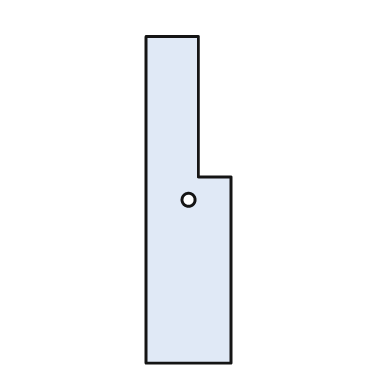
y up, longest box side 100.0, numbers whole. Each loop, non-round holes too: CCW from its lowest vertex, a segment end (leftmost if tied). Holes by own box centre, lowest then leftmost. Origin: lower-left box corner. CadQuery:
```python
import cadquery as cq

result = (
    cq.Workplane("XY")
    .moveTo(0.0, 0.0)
    .lineTo(26.0, 0.0)
    .lineTo(26.0, 57.0)
    .lineTo(16.0, 57.0)
    .lineTo(16.0, 100.0)
    .lineTo(0.0, 100.0)
    .close()
    .moveTo(13.0, 50.0)
    .circle(2.0)
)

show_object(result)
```